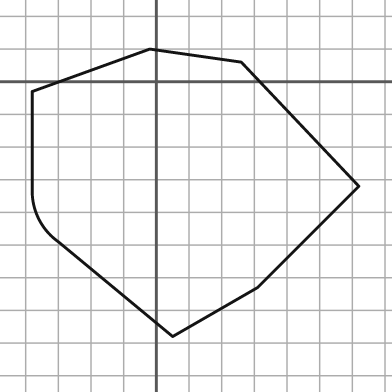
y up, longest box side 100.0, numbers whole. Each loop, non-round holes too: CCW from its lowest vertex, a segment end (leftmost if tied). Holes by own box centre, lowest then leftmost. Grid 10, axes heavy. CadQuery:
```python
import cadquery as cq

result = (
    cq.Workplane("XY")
    .moveTo(5.0, -78.0)
    .lineTo(31.0, -63.0)
    .lineTo(62.0, -32.0)
    .lineTo(26.0, 6.0)
    .lineTo(-2.0, 10.0)
    .lineTo(-38.0, -3.0)
    .lineTo(-38.0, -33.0)
    .threePointArc((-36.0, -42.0), (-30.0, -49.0))
    .close()
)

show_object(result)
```